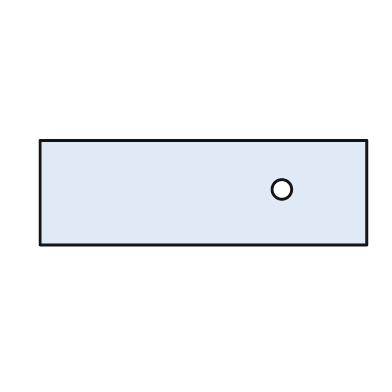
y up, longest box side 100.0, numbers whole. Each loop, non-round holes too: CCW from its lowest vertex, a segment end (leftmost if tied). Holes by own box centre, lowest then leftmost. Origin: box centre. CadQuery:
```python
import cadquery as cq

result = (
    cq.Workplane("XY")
    .moveTo(-50.0, -16.0)
    .lineTo(50.0, -16.0)
    .lineTo(50.0, 16.0)
    .lineTo(-50.0, 16.0)
    .close()
    .moveTo(24.0, 1.0)
    .circle(3.0)
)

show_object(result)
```